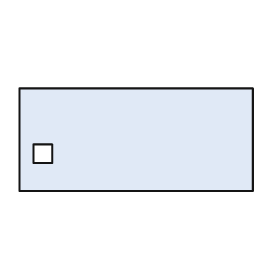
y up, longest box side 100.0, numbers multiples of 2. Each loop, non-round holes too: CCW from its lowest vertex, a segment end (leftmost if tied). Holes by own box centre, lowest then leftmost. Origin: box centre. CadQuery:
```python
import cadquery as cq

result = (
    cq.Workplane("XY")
    .moveTo(-50.0, -22.0)
    .lineTo(50.0, -22.0)
    .lineTo(50.0, 22.0)
    .lineTo(-50.0, 22.0)
    .close()
    .moveTo(-44.0, -10.0)
    .lineTo(-36.0, -10.0)
    .lineTo(-36.0, -2.0)
    .lineTo(-44.0, -2.0)
    .close()
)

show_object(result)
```